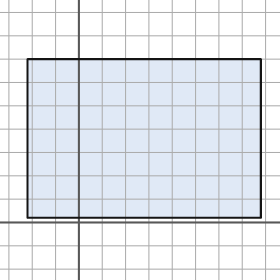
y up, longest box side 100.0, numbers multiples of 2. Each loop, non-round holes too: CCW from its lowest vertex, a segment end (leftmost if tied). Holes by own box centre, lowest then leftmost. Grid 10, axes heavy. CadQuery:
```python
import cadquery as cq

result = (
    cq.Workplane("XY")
    .moveTo(-22.0, 2.0)
    .lineTo(78.0, 2.0)
    .lineTo(78.0, 70.0)
    .lineTo(-22.0, 70.0)
    .close()
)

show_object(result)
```